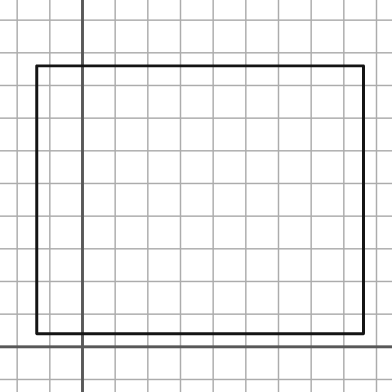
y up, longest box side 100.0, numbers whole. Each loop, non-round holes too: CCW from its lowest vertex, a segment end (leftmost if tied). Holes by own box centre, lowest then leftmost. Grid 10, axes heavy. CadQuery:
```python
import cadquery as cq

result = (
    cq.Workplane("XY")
    .moveTo(-14.0, 4.0)
    .lineTo(86.0, 4.0)
    .lineTo(86.0, 86.0)
    .lineTo(-14.0, 86.0)
    .close()
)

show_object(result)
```